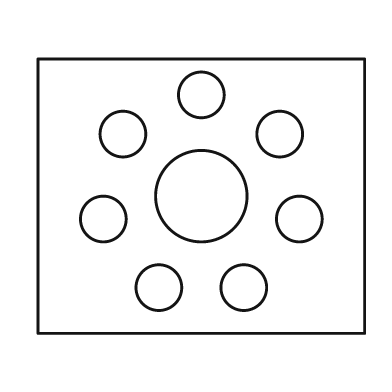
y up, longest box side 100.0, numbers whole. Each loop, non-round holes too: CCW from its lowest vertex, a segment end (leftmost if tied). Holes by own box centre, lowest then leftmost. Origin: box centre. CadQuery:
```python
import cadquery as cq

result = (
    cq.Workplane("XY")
    .moveTo(-50.0, -42.0)
    .lineTo(50.0, -42.0)
    .lineTo(50.0, 42.0)
    .lineTo(-50.0, 42.0)
    .close()
    .moveTo(-13.0, -28.0)
    .circle(7.0)
    .moveTo(13.0, -28.0)
    .circle(7.0)
    .moveTo(-30.0, -7.0)
    .circle(7.0)
    .moveTo(30.0, -7.0)
    .circle(7.0)
    .moveTo(0.0, 0.0)
    .circle(14.0)
    .moveTo(-24.0, 19.0)
    .circle(7.0)
    .moveTo(24.0, 19.0)
    .circle(7.0)
    .moveTo(0.0, 31.0)
    .circle(7.0)
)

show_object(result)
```